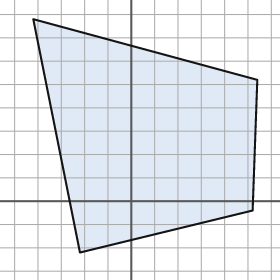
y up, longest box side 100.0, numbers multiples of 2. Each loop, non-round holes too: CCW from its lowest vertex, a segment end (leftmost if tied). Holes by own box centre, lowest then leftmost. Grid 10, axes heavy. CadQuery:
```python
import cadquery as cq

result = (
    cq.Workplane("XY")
    .moveTo(-22.0, -22.0)
    .lineTo(52.0, -4.0)
    .lineTo(54.0, 52.0)
    .lineTo(-42.0, 78.0)
    .close()
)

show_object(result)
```